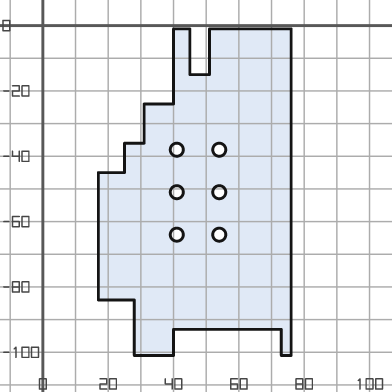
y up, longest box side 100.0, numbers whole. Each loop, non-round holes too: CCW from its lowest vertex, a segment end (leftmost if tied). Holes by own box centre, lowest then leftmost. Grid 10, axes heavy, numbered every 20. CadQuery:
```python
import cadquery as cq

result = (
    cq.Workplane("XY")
    .moveTo(28.0, -101.0)
    .lineTo(40.0, -101.0)
    .lineTo(40.0, -93.0)
    .lineTo(73.0, -93.0)
    .lineTo(73.0, -101.0)
    .lineTo(76.0, -101.0)
    .lineTo(76.0, -1.0)
    .lineTo(51.0, -1.0)
    .lineTo(51.0, -15.0)
    .lineTo(45.0, -15.0)
    .lineTo(45.0, -1.0)
    .lineTo(40.0, -1.0)
    .lineTo(40.0, -24.0)
    .lineTo(31.0, -24.0)
    .lineTo(31.0, -36.0)
    .lineTo(25.0, -36.0)
    .lineTo(25.0, -45.0)
    .lineTo(17.0, -45.0)
    .lineTo(17.0, -84.0)
    .lineTo(28.0, -84.0)
    .close()
    .moveTo(41.0, -64.0)
    .circle(2.0)
    .moveTo(54.0, -64.0)
    .circle(2.0)
    .moveTo(41.0, -51.0)
    .circle(2.0)
    .moveTo(54.0, -51.0)
    .circle(2.0)
    .moveTo(41.0, -38.0)
    .circle(2.0)
    .moveTo(54.0, -38.0)
    .circle(2.0)
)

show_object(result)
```